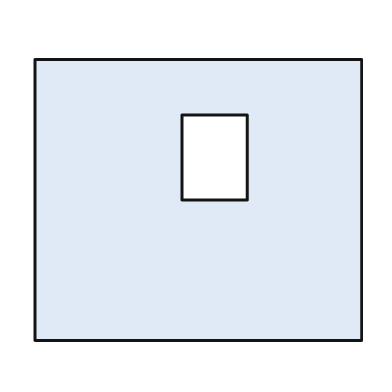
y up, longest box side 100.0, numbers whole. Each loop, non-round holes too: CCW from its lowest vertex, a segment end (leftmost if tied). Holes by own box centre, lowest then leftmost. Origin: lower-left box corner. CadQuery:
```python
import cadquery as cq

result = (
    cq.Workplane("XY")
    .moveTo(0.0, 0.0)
    .lineTo(100.0, 0.0)
    .lineTo(100.0, 86.0)
    .lineTo(0.0, 86.0)
    .close()
    .moveTo(45.0, 43.0)
    .lineTo(65.0, 43.0)
    .lineTo(65.0, 69.0)
    .lineTo(45.0, 69.0)
    .close()
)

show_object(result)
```